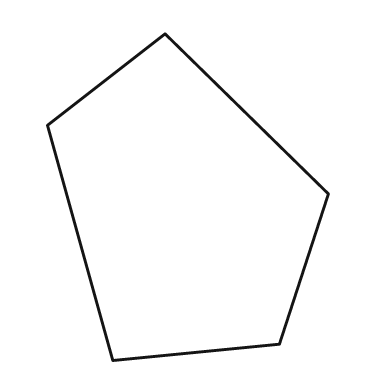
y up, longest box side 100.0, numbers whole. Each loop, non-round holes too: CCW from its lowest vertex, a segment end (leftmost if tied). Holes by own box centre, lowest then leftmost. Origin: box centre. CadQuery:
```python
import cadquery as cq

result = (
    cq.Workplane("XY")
    .moveTo(-23.0, -50.0)
    .lineTo(28.0, -45.0)
    .lineTo(43.0, 1.0)
    .lineTo(-7.0, 50.0)
    .lineTo(-43.0, 22.0)
    .close()
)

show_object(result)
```